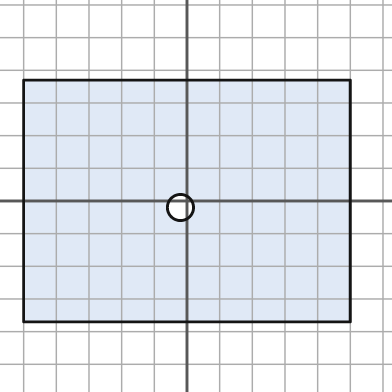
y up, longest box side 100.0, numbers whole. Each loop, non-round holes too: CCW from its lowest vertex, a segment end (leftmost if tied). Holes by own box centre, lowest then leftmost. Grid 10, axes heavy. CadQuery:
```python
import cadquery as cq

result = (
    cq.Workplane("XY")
    .moveTo(-50.0, -37.0)
    .lineTo(50.0, -37.0)
    .lineTo(50.0, 37.0)
    .lineTo(-50.0, 37.0)
    .close()
    .moveTo(-2.0, -2.0)
    .circle(4.0)
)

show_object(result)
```